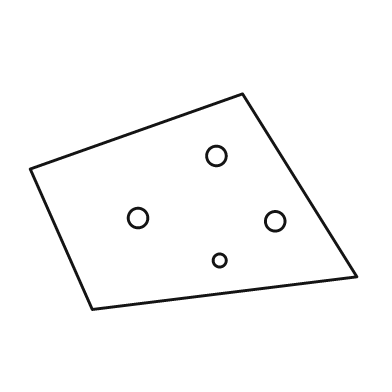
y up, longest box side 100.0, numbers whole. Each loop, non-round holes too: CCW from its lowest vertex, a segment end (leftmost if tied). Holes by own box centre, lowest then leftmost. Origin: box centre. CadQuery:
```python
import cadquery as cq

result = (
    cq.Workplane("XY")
    .moveTo(-31.0, -33.0)
    .lineTo(50.0, -23.0)
    .lineTo(15.0, 33.0)
    .lineTo(-50.0, 10.0)
    .close()
    .moveTo(8.0, -18.0)
    .circle(2.0)
    .moveTo(25.0, -6.0)
    .circle(3.0)
    .moveTo(-17.0, -5.0)
    .circle(3.0)
    .moveTo(7.0, 14.0)
    .circle(3.0)
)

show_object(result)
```